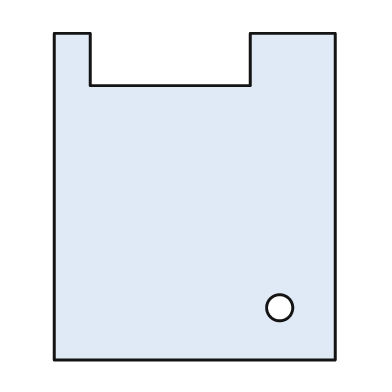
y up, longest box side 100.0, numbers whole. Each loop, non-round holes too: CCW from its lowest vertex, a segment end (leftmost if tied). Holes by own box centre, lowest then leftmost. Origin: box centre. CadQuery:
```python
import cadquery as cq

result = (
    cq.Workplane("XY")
    .moveTo(-43.0, -50.0)
    .lineTo(43.0, -50.0)
    .lineTo(43.0, 50.0)
    .lineTo(17.0, 50.0)
    .lineTo(17.0, 34.0)
    .lineTo(-32.0, 34.0)
    .lineTo(-32.0, 50.0)
    .lineTo(-43.0, 50.0)
    .close()
    .moveTo(26.0, -34.0)
    .circle(4.0)
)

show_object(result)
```